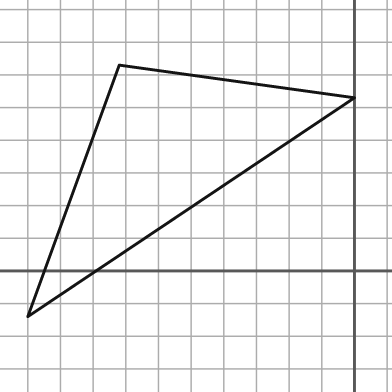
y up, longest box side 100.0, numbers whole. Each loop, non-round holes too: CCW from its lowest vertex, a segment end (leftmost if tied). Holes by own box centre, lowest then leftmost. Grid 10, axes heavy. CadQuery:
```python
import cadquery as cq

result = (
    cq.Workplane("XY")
    .moveTo(-100.0, -14.0)
    .lineTo(0.0, 53.0)
    .lineTo(-72.0, 63.0)
    .close()
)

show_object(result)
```